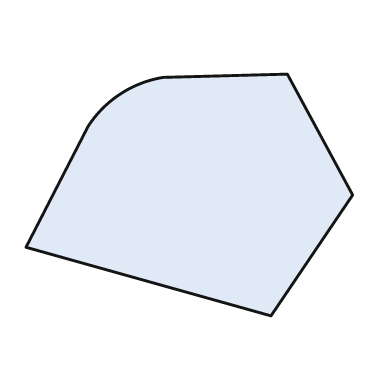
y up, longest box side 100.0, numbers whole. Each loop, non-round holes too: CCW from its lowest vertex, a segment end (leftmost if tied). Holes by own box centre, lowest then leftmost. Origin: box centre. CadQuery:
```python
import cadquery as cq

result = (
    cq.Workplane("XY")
    .moveTo(25.0, -37.0)
    .lineTo(50.0, 0.0)
    .lineTo(30.0, 37.0)
    .lineTo(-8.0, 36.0)
    .threePointArc((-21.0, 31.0), (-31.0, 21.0))
    .lineTo(-50.0, -16.0)
    .close()
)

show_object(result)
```